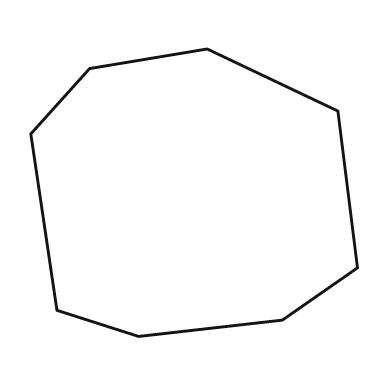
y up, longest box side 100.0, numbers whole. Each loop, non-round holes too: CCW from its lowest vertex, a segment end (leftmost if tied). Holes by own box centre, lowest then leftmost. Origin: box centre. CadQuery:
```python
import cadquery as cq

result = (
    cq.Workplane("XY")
    .moveTo(-17.0, -44.0)
    .lineTo(27.0, -39.0)
    .lineTo(50.0, -23.0)
    .lineTo(44.0, 25.0)
    .lineTo(4.0, 44.0)
    .lineTo(-32.0, 38.0)
    .lineTo(-50.0, 18.0)
    .lineTo(-42.0, -36.0)
    .close()
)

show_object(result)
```